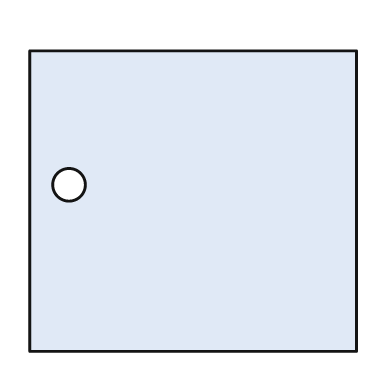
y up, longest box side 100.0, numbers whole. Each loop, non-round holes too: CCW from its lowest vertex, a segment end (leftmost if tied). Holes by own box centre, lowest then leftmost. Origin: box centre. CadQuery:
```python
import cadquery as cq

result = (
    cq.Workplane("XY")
    .moveTo(-50.0, -46.0)
    .lineTo(50.0, -46.0)
    .lineTo(50.0, 46.0)
    .lineTo(-50.0, 46.0)
    .close()
    .moveTo(-38.0, 5.0)
    .circle(5.0)
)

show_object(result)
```